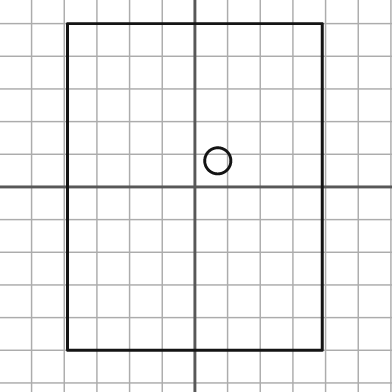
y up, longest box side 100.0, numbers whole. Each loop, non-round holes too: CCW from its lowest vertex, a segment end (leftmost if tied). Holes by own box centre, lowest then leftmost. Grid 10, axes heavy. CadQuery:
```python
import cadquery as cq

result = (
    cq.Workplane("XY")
    .moveTo(-39.0, -50.0)
    .lineTo(39.0, -50.0)
    .lineTo(39.0, 50.0)
    .lineTo(-39.0, 50.0)
    .close()
    .moveTo(7.0, 8.0)
    .circle(4.0)
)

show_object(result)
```